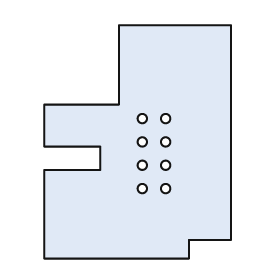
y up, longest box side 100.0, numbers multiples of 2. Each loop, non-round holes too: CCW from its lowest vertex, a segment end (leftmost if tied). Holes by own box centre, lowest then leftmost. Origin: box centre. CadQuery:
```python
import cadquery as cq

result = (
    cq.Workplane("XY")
    .moveTo(-40.0, -50.0)
    .lineTo(22.0, -50.0)
    .lineTo(22.0, -42.0)
    .lineTo(40.0, -42.0)
    .lineTo(40.0, 50.0)
    .lineTo(-8.0, 50.0)
    .lineTo(-8.0, 16.0)
    .lineTo(-40.0, 16.0)
    .lineTo(-40.0, -2.0)
    .lineTo(-16.0, -2.0)
    .lineTo(-16.0, -12.0)
    .lineTo(-40.0, -12.0)
    .close()
    .moveTo(2.0, -20.0)
    .circle(2.0)
    .moveTo(12.0, -20.0)
    .circle(2.0)
    .moveTo(2.0, -10.0)
    .circle(2.0)
    .moveTo(12.0, -10.0)
    .circle(2.0)
    .moveTo(2.0, 0.0)
    .circle(2.0)
    .moveTo(12.0, 0.0)
    .circle(2.0)
    .moveTo(2.0, 10.0)
    .circle(2.0)
    .moveTo(12.0, 10.0)
    .circle(2.0)
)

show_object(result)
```